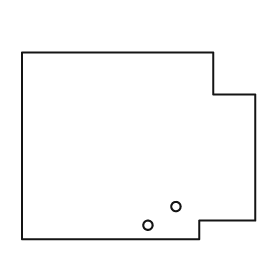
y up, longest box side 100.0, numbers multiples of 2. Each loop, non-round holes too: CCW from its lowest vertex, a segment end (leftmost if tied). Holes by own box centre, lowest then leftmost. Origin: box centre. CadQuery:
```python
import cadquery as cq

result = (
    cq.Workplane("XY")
    .moveTo(-50.0, -40.0)
    .lineTo(26.0, -40.0)
    .lineTo(26.0, -32.0)
    .lineTo(50.0, -32.0)
    .lineTo(50.0, 22.0)
    .lineTo(32.0, 22.0)
    .lineTo(32.0, 40.0)
    .lineTo(-50.0, 40.0)
    .close()
    .moveTo(4.0, -34.0)
    .circle(2.0)
    .moveTo(16.0, -26.0)
    .circle(2.0)
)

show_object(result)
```